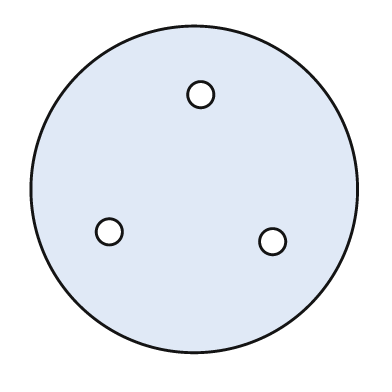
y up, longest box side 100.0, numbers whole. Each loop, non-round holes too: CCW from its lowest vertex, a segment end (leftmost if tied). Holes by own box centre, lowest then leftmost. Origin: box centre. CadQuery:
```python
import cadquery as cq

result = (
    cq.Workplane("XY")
    .moveTo(0.0, 0.0)
    .circle(50.0)
    .moveTo(24.0, -16.0)
    .circle(4.0)
    .moveTo(-26.0, -13.0)
    .circle(4.0)
    .moveTo(2.0, 29.0)
    .circle(4.0)
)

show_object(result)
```